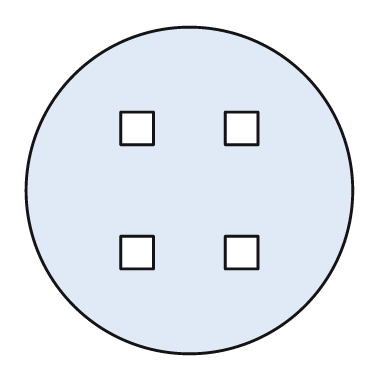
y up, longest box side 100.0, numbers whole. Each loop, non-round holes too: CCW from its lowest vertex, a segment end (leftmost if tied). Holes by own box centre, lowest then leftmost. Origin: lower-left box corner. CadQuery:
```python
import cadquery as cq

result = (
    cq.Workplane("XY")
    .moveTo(50.0, 50.0)
    .circle(50.0)
    .moveTo(29.0, 26.0)
    .lineTo(39.0, 26.0)
    .lineTo(39.0, 36.0)
    .lineTo(29.0, 36.0)
    .close()
    .moveTo(61.0, 26.0)
    .lineTo(71.0, 26.0)
    .lineTo(71.0, 36.0)
    .lineTo(61.0, 36.0)
    .close()
    .moveTo(29.0, 64.0)
    .lineTo(39.0, 64.0)
    .lineTo(39.0, 74.0)
    .lineTo(29.0, 74.0)
    .close()
    .moveTo(61.0, 64.0)
    .lineTo(71.0, 64.0)
    .lineTo(71.0, 74.0)
    .lineTo(61.0, 74.0)
    .close()
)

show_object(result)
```